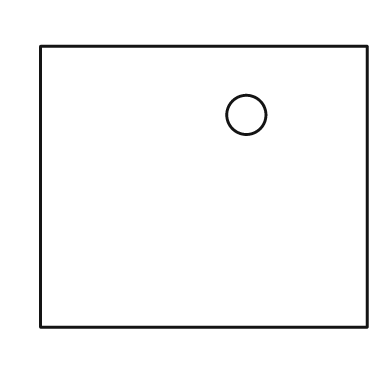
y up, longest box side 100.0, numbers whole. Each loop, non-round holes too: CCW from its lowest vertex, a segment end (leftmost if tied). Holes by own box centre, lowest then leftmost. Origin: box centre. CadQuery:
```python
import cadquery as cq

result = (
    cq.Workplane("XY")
    .moveTo(-50.0, -43.0)
    .lineTo(50.0, -43.0)
    .lineTo(50.0, 43.0)
    .lineTo(-50.0, 43.0)
    .close()
    .moveTo(13.0, 22.0)
    .circle(6.0)
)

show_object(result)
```